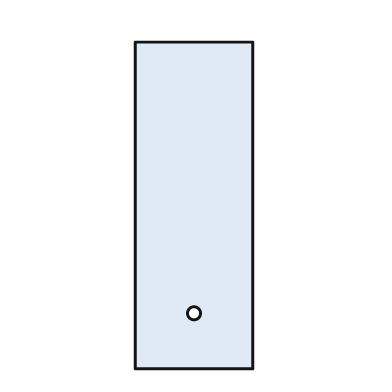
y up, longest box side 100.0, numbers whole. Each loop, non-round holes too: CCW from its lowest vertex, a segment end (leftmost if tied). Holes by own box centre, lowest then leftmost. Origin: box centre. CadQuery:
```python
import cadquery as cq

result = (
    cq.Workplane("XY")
    .moveTo(-18.0, -50.0)
    .lineTo(18.0, -50.0)
    .lineTo(18.0, 50.0)
    .lineTo(-18.0, 50.0)
    .close()
    .moveTo(0.0, -33.0)
    .circle(2.0)
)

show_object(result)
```